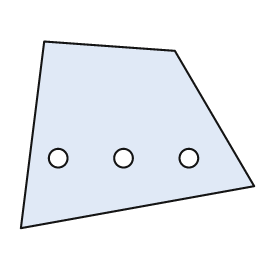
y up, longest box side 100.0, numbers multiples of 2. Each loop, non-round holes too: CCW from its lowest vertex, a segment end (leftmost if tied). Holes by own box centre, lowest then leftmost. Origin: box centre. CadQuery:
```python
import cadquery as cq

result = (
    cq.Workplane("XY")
    .moveTo(-50.0, -40.0)
    .lineTo(50.0, -22.0)
    .lineTo(16.0, 36.0)
    .lineTo(-40.0, 40.0)
    .close()
    .moveTo(-34.0, -10.0)
    .circle(4.0)
    .moveTo(-6.0, -10.0)
    .circle(4.0)
    .moveTo(22.0, -10.0)
    .circle(4.0)
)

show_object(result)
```